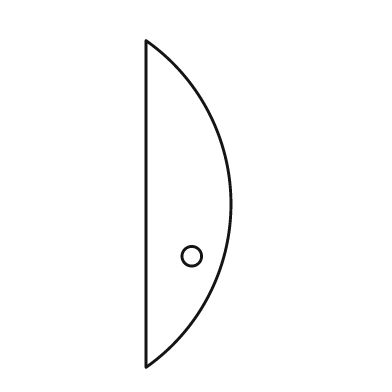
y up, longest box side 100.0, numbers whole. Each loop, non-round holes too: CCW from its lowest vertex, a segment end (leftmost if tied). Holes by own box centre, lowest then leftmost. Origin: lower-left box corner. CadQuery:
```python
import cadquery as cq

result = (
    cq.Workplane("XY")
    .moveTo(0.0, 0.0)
    .threePointArc((26.0, 50.0), (0.0, 100.0))
    .close()
    .moveTo(14.0, 34.0)
    .circle(3.0)
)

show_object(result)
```